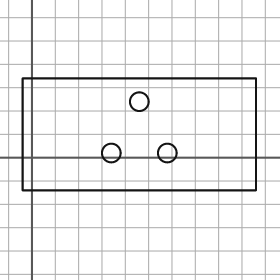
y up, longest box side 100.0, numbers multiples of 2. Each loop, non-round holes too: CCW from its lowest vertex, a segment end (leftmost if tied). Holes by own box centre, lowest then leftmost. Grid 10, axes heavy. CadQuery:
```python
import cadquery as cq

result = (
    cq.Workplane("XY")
    .moveTo(-4.0, -14.0)
    .lineTo(96.0, -14.0)
    .lineTo(96.0, 34.0)
    .lineTo(-4.0, 34.0)
    .close()
    .moveTo(34.0, 2.0)
    .circle(4.0)
    .moveTo(58.0, 2.0)
    .circle(4.0)
    .moveTo(46.0, 24.0)
    .circle(4.0)
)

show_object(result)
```